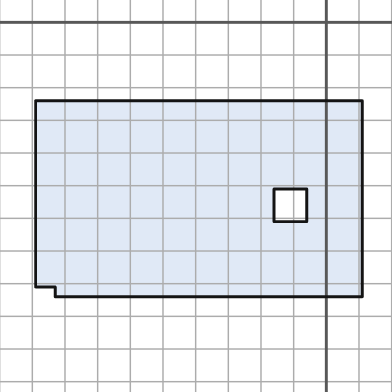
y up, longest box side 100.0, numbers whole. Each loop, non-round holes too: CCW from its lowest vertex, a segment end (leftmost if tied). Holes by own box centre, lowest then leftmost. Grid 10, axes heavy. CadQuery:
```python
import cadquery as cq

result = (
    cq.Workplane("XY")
    .moveTo(-83.0, -84.0)
    .lineTo(11.0, -84.0)
    .lineTo(11.0, -24.0)
    .lineTo(-89.0, -24.0)
    .lineTo(-89.0, -81.0)
    .lineTo(-83.0, -81.0)
    .close()
    .moveTo(-16.0, -61.0)
    .lineTo(-6.0, -61.0)
    .lineTo(-6.0, -51.0)
    .lineTo(-16.0, -51.0)
    .close()
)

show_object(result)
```